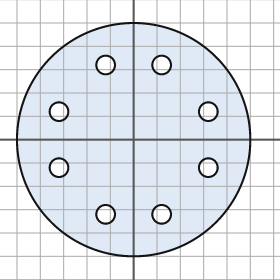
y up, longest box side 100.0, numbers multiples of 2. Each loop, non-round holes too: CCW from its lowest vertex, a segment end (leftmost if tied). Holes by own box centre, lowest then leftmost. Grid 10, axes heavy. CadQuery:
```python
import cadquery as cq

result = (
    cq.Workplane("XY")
    .moveTo(0.0, 0.0)
    .circle(50.0)
    .moveTo(-12.0, -32.0)
    .circle(4.0)
    .moveTo(12.0, -32.0)
    .circle(4.0)
    .moveTo(-32.0, -12.0)
    .circle(4.0)
    .moveTo(32.0, -12.0)
    .circle(4.0)
    .moveTo(-32.0, 12.0)
    .circle(4.0)
    .moveTo(32.0, 12.0)
    .circle(4.0)
    .moveTo(-12.0, 32.0)
    .circle(4.0)
    .moveTo(12.0, 32.0)
    .circle(4.0)
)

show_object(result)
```